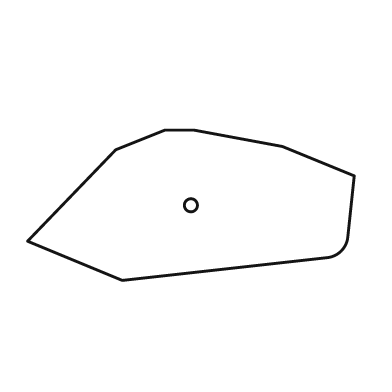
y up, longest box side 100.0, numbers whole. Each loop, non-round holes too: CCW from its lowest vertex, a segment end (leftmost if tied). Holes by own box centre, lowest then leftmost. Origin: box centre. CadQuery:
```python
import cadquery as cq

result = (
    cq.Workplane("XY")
    .moveTo(-21.0, -23.0)
    .lineTo(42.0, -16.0)
    .threePointArc((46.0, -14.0), (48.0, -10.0))
    .lineTo(50.0, 9.0)
    .lineTo(28.0, 18.0)
    .lineTo(1.0, 23.0)
    .lineTo(-8.0, 23.0)
    .lineTo(-23.0, 17.0)
    .lineTo(-50.0, -11.0)
    .close()
    .moveTo(0.0, 0.0)
    .circle(2.0)
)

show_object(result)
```